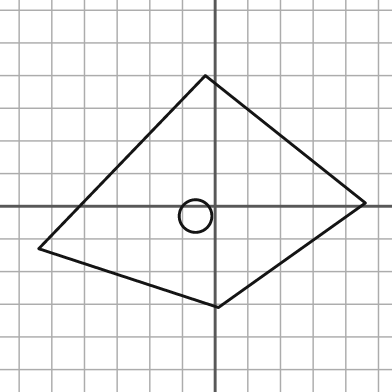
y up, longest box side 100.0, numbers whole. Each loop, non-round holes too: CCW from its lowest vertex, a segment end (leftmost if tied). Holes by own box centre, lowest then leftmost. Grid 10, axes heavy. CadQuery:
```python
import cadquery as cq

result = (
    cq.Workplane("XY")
    .moveTo(1.0, -31.0)
    .lineTo(46.0, 1.0)
    .lineTo(-3.0, 40.0)
    .lineTo(-54.0, -13.0)
    .close()
    .moveTo(-6.0, -3.0)
    .circle(5.0)
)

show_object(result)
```